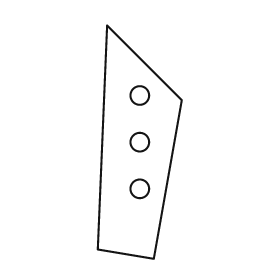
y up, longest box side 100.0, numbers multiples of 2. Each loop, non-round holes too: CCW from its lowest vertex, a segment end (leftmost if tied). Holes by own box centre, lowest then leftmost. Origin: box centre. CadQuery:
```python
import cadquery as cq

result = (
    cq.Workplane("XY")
    .moveTo(6.0, -50.0)
    .lineTo(18.0, 18.0)
    .lineTo(-14.0, 50.0)
    .lineTo(-18.0, -46.0)
    .close()
    .moveTo(0.0, -20.0)
    .circle(4.0)
    .moveTo(0.0, 0.0)
    .circle(4.0)
    .moveTo(0.0, 20.0)
    .circle(4.0)
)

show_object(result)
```